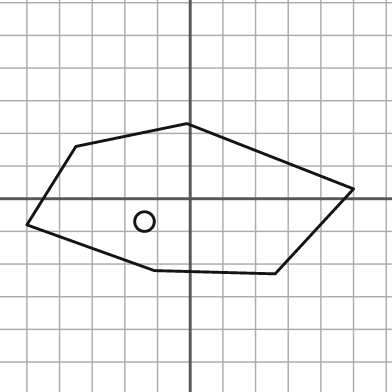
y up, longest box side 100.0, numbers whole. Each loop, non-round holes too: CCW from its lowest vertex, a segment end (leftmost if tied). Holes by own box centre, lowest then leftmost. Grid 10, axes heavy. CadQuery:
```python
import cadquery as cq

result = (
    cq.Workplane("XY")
    .moveTo(26.0, -23.0)
    .lineTo(50.0, 3.0)
    .lineTo(-1.0, 23.0)
    .lineTo(-35.0, 16.0)
    .lineTo(-50.0, -8.0)
    .lineTo(-11.0, -22.0)
    .close()
    .moveTo(-14.0, -7.0)
    .circle(3.0)
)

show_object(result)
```